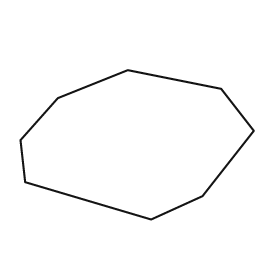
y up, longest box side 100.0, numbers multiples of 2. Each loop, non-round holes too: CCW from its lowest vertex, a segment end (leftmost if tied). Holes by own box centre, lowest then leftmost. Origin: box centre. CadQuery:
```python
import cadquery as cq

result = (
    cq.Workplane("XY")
    .moveTo(6.0, -32.0)
    .lineTo(28.0, -22.0)
    .lineTo(50.0, 6.0)
    .lineTo(36.0, 24.0)
    .lineTo(-4.0, 32.0)
    .lineTo(-34.0, 20.0)
    .lineTo(-50.0, 2.0)
    .lineTo(-48.0, -16.0)
    .close()
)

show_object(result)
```